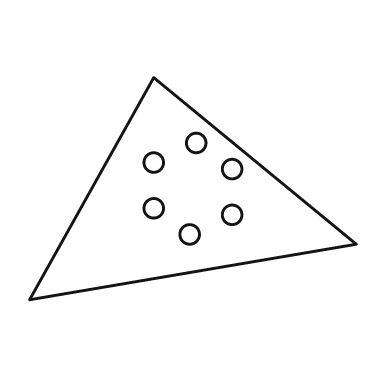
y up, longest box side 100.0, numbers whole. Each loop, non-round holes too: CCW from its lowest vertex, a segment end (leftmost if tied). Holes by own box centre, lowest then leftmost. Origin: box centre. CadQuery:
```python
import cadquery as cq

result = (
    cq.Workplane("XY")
    .moveTo(-50.0, -34.0)
    .lineTo(50.0, -17.0)
    .lineTo(-12.0, 34.0)
    .close()
    .moveTo(-1.0, -14.0)
    .circle(3.0)
    .moveTo(12.0, -8.0)
    .circle(3.0)
    .moveTo(-12.0, -6.0)
    .circle(3.0)
    .moveTo(12.0, 6.0)
    .circle(3.0)
    .moveTo(-12.0, 8.0)
    .circle(3.0)
    .moveTo(1.0, 14.0)
    .circle(3.0)
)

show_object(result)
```